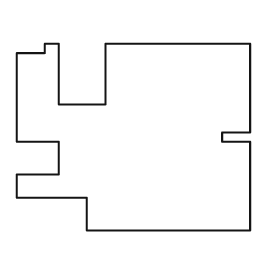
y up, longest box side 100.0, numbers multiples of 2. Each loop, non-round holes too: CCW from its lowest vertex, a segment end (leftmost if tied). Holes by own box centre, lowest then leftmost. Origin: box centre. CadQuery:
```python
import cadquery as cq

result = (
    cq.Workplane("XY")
    .moveTo(-20.0, -40.0)
    .lineTo(50.0, -40.0)
    .lineTo(50.0, -2.0)
    .lineTo(38.0, -2.0)
    .lineTo(38.0, 2.0)
    .lineTo(50.0, 2.0)
    .lineTo(50.0, 40.0)
    .lineTo(-12.0, 40.0)
    .lineTo(-12.0, 14.0)
    .lineTo(-32.0, 14.0)
    .lineTo(-32.0, 40.0)
    .lineTo(-38.0, 40.0)
    .lineTo(-38.0, 36.0)
    .lineTo(-50.0, 36.0)
    .lineTo(-50.0, -2.0)
    .lineTo(-32.0, -2.0)
    .lineTo(-32.0, -16.0)
    .lineTo(-50.0, -16.0)
    .lineTo(-50.0, -26.0)
    .lineTo(-20.0, -26.0)
    .close()
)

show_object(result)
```